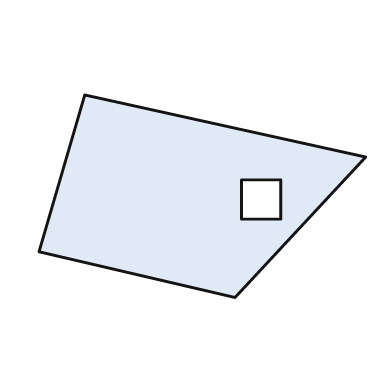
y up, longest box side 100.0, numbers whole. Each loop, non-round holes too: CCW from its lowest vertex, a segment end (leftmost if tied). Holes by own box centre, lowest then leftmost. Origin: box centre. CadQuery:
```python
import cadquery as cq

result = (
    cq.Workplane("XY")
    .moveTo(10.0, -31.0)
    .lineTo(50.0, 12.0)
    .lineTo(-36.0, 31.0)
    .lineTo(-50.0, -17.0)
    .close()
    .moveTo(12.0, -7.0)
    .lineTo(24.0, -7.0)
    .lineTo(24.0, 5.0)
    .lineTo(12.0, 5.0)
    .close()
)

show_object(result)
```